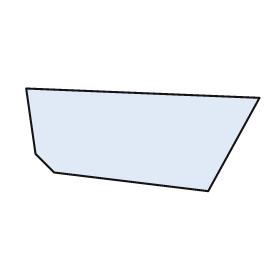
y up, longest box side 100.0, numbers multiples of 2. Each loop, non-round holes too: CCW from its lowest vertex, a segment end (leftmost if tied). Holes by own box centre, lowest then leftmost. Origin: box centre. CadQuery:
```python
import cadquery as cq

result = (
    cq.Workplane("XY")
    .moveTo(28.0, -22.0)
    .lineTo(50.0, 18.0)
    .lineTo(-50.0, 22.0)
    .lineTo(-46.0, -6.0)
    .lineTo(-38.0, -14.0)
    .close()
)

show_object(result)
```